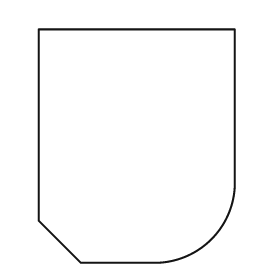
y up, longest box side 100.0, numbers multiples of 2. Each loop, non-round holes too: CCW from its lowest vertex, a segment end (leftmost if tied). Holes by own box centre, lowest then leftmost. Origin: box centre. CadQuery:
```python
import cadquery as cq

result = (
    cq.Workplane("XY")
    .moveTo(-24.0, -50.0)
    .lineTo(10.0, -50.0)
    .threePointArc((32.0, -40.0), (42.0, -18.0))
    .lineTo(42.0, 50.0)
    .lineTo(-42.0, 50.0)
    .lineTo(-42.0, -32.0)
    .close()
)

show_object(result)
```